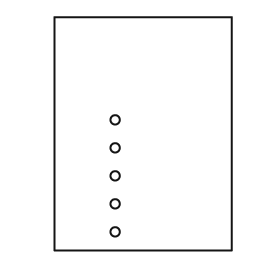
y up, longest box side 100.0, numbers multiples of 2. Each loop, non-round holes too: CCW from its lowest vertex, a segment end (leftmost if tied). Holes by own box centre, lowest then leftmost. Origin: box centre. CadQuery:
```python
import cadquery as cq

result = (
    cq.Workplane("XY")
    .moveTo(-38.0, -50.0)
    .lineTo(38.0, -50.0)
    .lineTo(38.0, 50.0)
    .lineTo(-38.0, 50.0)
    .close()
    .moveTo(-12.0, -42.0)
    .circle(2.0)
    .moveTo(-12.0, -30.0)
    .circle(2.0)
    .moveTo(-12.0, -18.0)
    .circle(2.0)
    .moveTo(-12.0, -6.0)
    .circle(2.0)
    .moveTo(-12.0, 6.0)
    .circle(2.0)
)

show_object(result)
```